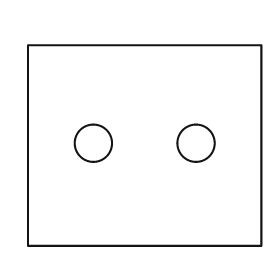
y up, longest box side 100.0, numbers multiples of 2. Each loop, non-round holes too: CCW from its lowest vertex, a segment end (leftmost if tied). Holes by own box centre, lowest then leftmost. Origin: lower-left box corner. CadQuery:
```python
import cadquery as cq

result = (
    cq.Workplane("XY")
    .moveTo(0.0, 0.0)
    .lineTo(100.0, 0.0)
    .lineTo(100.0, 86.0)
    .lineTo(0.0, 86.0)
    .close()
    .moveTo(28.0, 44.0)
    .circle(8.0)
    .moveTo(72.0, 44.0)
    .circle(8.0)
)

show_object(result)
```